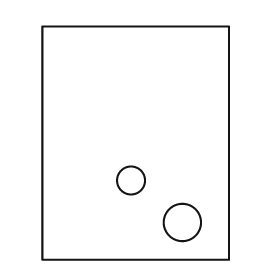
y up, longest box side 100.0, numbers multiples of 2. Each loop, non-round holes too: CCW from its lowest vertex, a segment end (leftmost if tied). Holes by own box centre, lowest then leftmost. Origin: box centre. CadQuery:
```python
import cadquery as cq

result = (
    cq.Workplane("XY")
    .moveTo(-40.0, -50.0)
    .lineTo(40.0, -50.0)
    .lineTo(40.0, 50.0)
    .lineTo(-40.0, 50.0)
    .close()
    .moveTo(20.0, -34.0)
    .circle(8.0)
    .moveTo(-2.0, -16.0)
    .circle(6.0)
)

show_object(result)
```